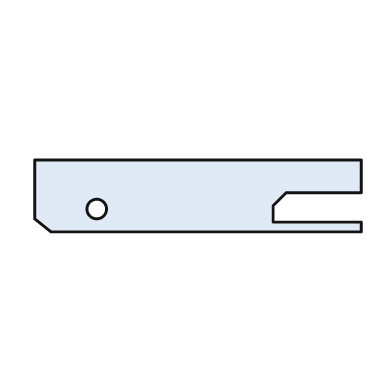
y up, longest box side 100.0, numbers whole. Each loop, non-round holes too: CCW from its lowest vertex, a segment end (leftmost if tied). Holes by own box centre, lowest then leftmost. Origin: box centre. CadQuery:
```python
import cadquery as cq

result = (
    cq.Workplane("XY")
    .moveTo(-45.0, -11.0)
    .lineTo(50.0, -11.0)
    .lineTo(50.0, -8.0)
    .lineTo(23.0, -8.0)
    .lineTo(23.0, -3.0)
    .lineTo(27.0, 1.0)
    .lineTo(50.0, 1.0)
    .lineTo(50.0, 11.0)
    .lineTo(-50.0, 11.0)
    .lineTo(-50.0, -7.0)
    .close()
    .moveTo(-31.0, -4.0)
    .circle(3.0)
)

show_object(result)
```